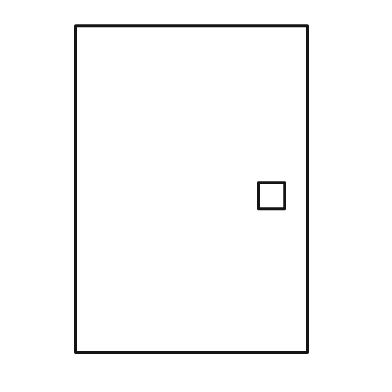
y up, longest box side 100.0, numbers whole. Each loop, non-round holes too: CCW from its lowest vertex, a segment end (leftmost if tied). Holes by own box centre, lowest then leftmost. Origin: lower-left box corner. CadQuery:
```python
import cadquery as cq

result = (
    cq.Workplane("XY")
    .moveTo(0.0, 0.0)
    .lineTo(71.0, 0.0)
    .lineTo(71.0, 100.0)
    .lineTo(0.0, 100.0)
    .close()
    .moveTo(56.0, 44.0)
    .lineTo(64.0, 44.0)
    .lineTo(64.0, 52.0)
    .lineTo(56.0, 52.0)
    .close()
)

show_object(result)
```